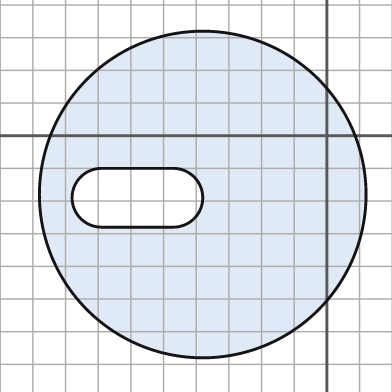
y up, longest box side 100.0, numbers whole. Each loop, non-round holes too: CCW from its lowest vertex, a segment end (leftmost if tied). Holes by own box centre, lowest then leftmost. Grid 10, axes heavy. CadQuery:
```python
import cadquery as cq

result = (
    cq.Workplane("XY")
    .moveTo(-38.0, -18.0)
    .circle(50.0)
    .moveTo(-69.0, -28.0)
    .lineTo(-47.0, -28.0)
    .threePointArc((-38.0, -19.0), (-47.0, -10.0))
    .lineTo(-69.0, -10.0)
    .threePointArc((-78.0, -19.0), (-69.0, -28.0))
    .close()
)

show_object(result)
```